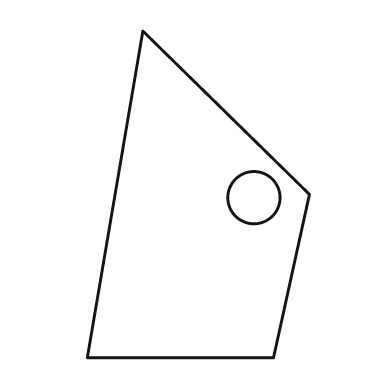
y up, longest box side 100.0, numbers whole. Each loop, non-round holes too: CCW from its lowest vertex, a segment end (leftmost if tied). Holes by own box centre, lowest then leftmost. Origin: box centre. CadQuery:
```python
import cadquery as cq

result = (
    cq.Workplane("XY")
    .moveTo(-34.0, -50.0)
    .lineTo(23.0, -50.0)
    .lineTo(34.0, 0.0)
    .lineTo(-17.0, 50.0)
    .close()
    .moveTo(17.0, -1.0)
    .circle(8.0)
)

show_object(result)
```